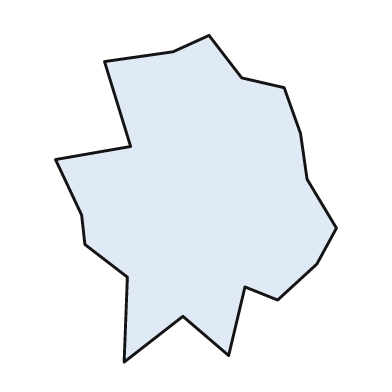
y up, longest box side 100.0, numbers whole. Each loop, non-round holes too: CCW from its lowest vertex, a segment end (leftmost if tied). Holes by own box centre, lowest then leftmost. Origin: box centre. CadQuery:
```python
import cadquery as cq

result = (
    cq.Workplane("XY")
    .moveTo(-22.0, -50.0)
    .lineTo(-4.0, -36.0)
    .lineTo(10.0, -48.0)
    .lineTo(15.0, -27.0)
    .lineTo(25.0, -31.0)
    .lineTo(37.0, -20.0)
    .lineTo(43.0, -9.0)
    .lineTo(34.0, 6.0)
    .lineTo(32.0, 20.0)
    .lineTo(27.0, 34.0)
    .lineTo(14.0, 37.0)
    .lineTo(4.0, 50.0)
    .lineTo(-7.0, 45.0)
    .lineTo(-28.0, 42.0)
    .lineTo(-20.0, 16.0)
    .lineTo(-43.0, 12.0)
    .lineTo(-35.0, -5.0)
    .lineTo(-34.0, -14.0)
    .lineTo(-21.0, -24.0)
    .close()
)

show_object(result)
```